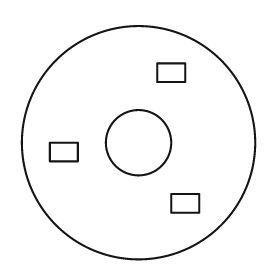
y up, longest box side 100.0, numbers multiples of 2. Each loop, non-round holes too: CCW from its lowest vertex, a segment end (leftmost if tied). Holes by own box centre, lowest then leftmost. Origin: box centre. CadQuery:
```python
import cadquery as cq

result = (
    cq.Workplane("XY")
    .moveTo(0.0, 0.0)
    .circle(50.0)
    .moveTo(14.0, -30.0)
    .lineTo(26.0, -30.0)
    .lineTo(26.0, -22.0)
    .lineTo(14.0, -22.0)
    .close()
    .moveTo(-38.0, -8.0)
    .lineTo(-26.0, -8.0)
    .lineTo(-26.0, 0.0)
    .lineTo(-38.0, 0.0)
    .close()
    .moveTo(0.0, 0.0)
    .circle(14.0)
    .moveTo(8.0, 26.0)
    .lineTo(20.0, 26.0)
    .lineTo(20.0, 34.0)
    .lineTo(8.0, 34.0)
    .close()
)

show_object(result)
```